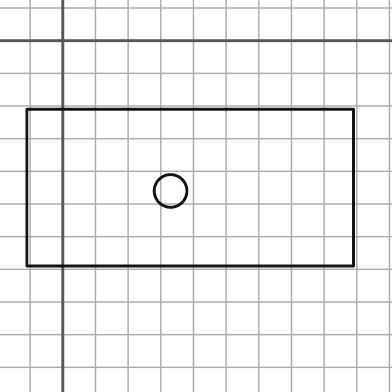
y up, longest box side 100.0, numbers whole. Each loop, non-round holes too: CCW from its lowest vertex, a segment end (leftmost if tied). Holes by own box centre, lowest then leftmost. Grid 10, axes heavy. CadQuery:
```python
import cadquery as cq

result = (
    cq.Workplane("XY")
    .moveTo(-11.0, -69.0)
    .lineTo(89.0, -69.0)
    .lineTo(89.0, -21.0)
    .lineTo(-11.0, -21.0)
    .close()
    .moveTo(33.0, -46.0)
    .circle(5.0)
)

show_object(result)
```